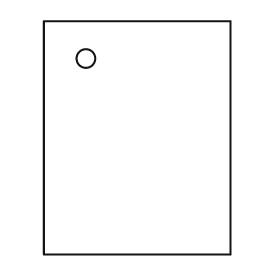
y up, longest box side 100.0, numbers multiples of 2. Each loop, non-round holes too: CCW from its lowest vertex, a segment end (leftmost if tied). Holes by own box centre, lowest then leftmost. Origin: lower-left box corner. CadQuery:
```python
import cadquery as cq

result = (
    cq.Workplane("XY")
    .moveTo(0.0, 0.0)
    .lineTo(80.0, 0.0)
    .lineTo(80.0, 100.0)
    .lineTo(0.0, 100.0)
    .close()
    .moveTo(18.0, 84.0)
    .circle(4.0)
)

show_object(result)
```